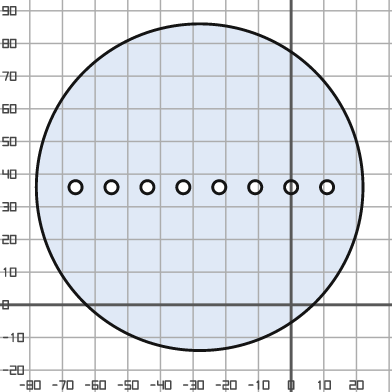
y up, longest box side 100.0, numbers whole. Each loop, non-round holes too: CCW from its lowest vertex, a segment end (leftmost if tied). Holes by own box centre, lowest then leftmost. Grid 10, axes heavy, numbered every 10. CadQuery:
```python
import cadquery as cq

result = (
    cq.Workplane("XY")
    .moveTo(-28.0, 36.0)
    .circle(50.0)
    .moveTo(-66.0, 36.0)
    .circle(2.0)
    .moveTo(-55.0, 36.0)
    .circle(2.0)
    .moveTo(-44.0, 36.0)
    .circle(2.0)
    .moveTo(-33.0, 36.0)
    .circle(2.0)
    .moveTo(-22.0, 36.0)
    .circle(2.0)
    .moveTo(-11.0, 36.0)
    .circle(2.0)
    .moveTo(0.0, 36.0)
    .circle(2.0)
    .moveTo(11.0, 36.0)
    .circle(2.0)
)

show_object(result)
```